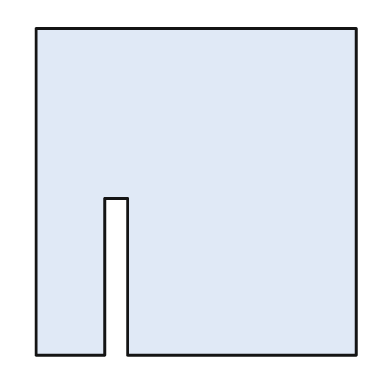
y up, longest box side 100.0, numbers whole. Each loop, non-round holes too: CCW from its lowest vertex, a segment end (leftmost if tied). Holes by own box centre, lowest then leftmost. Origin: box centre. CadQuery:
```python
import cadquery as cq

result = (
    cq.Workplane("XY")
    .moveTo(-49.0, -50.0)
    .lineTo(-28.0, -50.0)
    .lineTo(-28.0, -2.0)
    .lineTo(-21.0, -2.0)
    .lineTo(-21.0, -50.0)
    .lineTo(49.0, -50.0)
    .lineTo(49.0, 50.0)
    .lineTo(-49.0, 50.0)
    .close()
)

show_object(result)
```